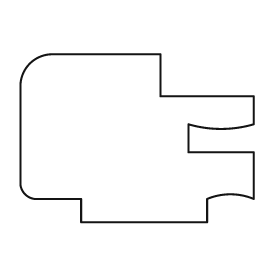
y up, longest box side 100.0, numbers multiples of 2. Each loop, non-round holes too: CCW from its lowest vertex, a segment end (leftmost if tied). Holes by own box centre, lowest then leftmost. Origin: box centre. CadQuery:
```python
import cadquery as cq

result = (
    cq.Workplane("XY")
    .moveTo(-24.0, -36.0)
    .lineTo(30.0, -36.0)
    .lineTo(30.0, -26.0)
    .threePointArc((40.0, -24.0), (50.0, -26.0))
    .lineTo(50.0, -6.0)
    .lineTo(22.0, -6.0)
    .lineTo(22.0, 6.0)
    .threePointArc((36.0, 4.0), (50.0, 6.0))
    .lineTo(50.0, 18.0)
    .lineTo(10.0, 18.0)
    .lineTo(10.0, 36.0)
    .lineTo(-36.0, 36.0)
    .threePointArc((-46.0, 32.0), (-50.0, 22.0))
    .lineTo(-50.0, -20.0)
    .threePointArc((-48.0, -24.0), (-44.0, -26.0))
    .lineTo(-24.0, -26.0)
    .close()
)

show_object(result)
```